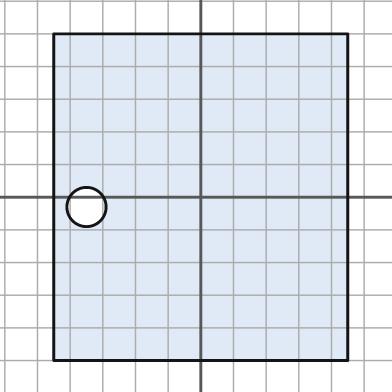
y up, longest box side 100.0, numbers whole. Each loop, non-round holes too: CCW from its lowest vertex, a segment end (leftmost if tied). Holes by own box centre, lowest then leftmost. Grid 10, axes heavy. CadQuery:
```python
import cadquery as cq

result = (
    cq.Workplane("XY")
    .moveTo(-45.0, -50.0)
    .lineTo(45.0, -50.0)
    .lineTo(45.0, 50.0)
    .lineTo(-45.0, 50.0)
    .close()
    .moveTo(-35.0, -3.0)
    .circle(6.0)
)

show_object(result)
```